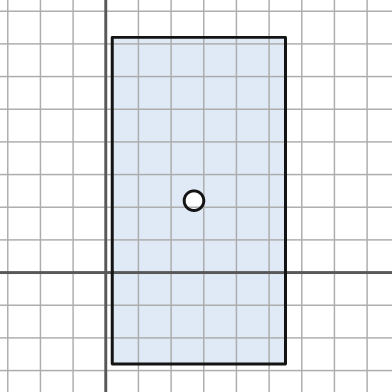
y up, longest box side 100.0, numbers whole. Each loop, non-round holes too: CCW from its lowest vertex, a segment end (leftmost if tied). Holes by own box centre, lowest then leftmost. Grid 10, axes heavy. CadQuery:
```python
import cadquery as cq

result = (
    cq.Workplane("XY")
    .moveTo(2.0, -28.0)
    .lineTo(55.0, -28.0)
    .lineTo(55.0, 72.0)
    .lineTo(2.0, 72.0)
    .close()
    .moveTo(27.0, 22.0)
    .circle(3.0)
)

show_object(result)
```